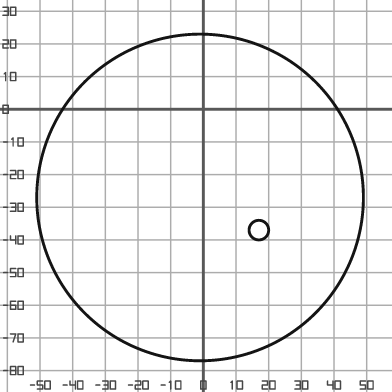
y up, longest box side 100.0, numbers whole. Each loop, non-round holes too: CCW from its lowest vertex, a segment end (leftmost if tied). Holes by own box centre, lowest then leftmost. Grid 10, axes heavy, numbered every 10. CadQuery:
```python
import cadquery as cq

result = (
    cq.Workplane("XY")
    .moveTo(-1.0, -27.0)
    .circle(50.0)
    .moveTo(17.0, -37.0)
    .circle(3.0)
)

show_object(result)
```